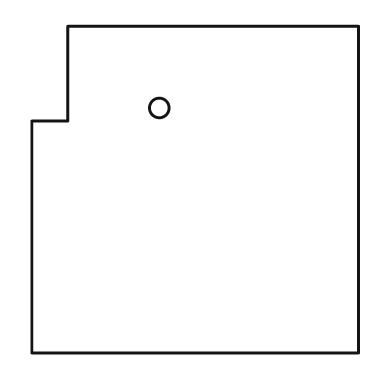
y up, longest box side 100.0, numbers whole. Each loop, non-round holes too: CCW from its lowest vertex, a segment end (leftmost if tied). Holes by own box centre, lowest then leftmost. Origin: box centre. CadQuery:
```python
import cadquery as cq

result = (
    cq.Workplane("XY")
    .moveTo(-50.0, -50.0)
    .lineTo(50.0, -50.0)
    .lineTo(50.0, 50.0)
    .lineTo(-39.0, 50.0)
    .lineTo(-39.0, 21.0)
    .lineTo(-50.0, 21.0)
    .close()
    .moveTo(-11.0, 25.0)
    .circle(3.0)
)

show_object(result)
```